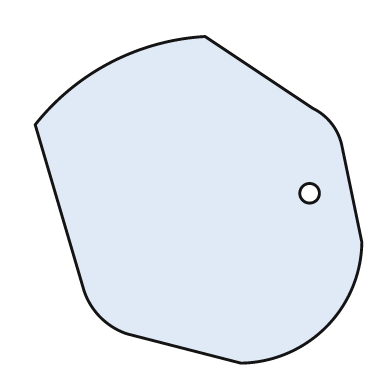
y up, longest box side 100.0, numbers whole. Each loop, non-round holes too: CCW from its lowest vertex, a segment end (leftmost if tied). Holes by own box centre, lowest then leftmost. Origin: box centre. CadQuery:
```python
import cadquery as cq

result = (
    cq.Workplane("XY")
    .moveTo(13.0, -50.0)
    .threePointArc((39.0, -39.0), (50.0, -13.0))
    .lineTo(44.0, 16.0)
    .threePointArc((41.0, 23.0), (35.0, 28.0))
    .lineTo(2.0, 50.0)
    .threePointArc((-27.0, 42.0), (-50.0, 23.0))
    .lineTo(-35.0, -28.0)
    .threePointArc((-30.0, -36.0), (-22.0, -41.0))
    .close()
    .moveTo(34.0, 2.0)
    .circle(3.0)
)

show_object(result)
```